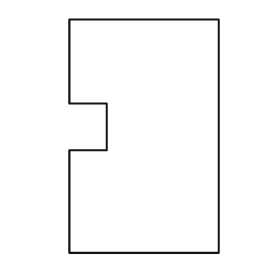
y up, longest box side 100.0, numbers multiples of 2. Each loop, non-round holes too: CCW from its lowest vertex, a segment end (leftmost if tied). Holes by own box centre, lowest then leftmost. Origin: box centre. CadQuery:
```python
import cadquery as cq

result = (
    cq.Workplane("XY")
    .moveTo(-32.0, -50.0)
    .lineTo(32.0, -50.0)
    .lineTo(32.0, 50.0)
    .lineTo(-32.0, 50.0)
    .lineTo(-32.0, 14.0)
    .lineTo(-16.0, 14.0)
    .lineTo(-16.0, -6.0)
    .lineTo(-32.0, -6.0)
    .close()
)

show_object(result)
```